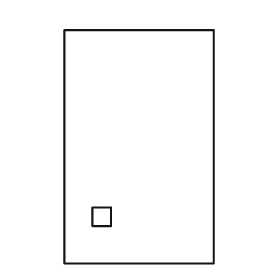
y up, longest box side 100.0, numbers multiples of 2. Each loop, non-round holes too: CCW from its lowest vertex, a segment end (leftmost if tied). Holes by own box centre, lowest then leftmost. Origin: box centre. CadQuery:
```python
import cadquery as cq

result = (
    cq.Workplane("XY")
    .moveTo(-32.0, -50.0)
    .lineTo(32.0, -50.0)
    .lineTo(32.0, 50.0)
    .lineTo(-32.0, 50.0)
    .close()
    .moveTo(-20.0, -34.0)
    .lineTo(-12.0, -34.0)
    .lineTo(-12.0, -26.0)
    .lineTo(-20.0, -26.0)
    .close()
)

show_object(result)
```